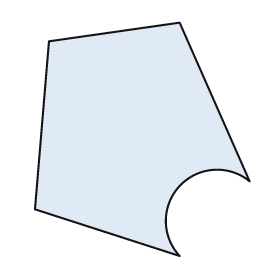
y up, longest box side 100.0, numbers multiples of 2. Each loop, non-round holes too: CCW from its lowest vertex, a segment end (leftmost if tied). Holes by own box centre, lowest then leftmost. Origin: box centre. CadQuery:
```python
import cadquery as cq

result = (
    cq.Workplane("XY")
    .moveTo(16.0, -50.0)
    .threePointArc((16.0, -20.0), (46.0, -18.0))
    .lineTo(16.0, 50.0)
    .lineTo(-40.0, 42.0)
    .lineTo(-46.0, -30.0)
    .close()
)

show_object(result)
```